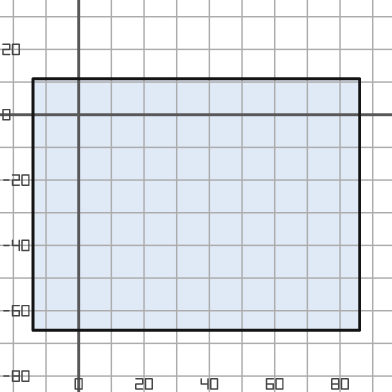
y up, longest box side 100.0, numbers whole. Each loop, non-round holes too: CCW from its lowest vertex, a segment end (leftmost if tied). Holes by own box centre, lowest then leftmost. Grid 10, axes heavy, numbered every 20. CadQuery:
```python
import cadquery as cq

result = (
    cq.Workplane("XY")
    .moveTo(-14.0, -66.0)
    .lineTo(86.0, -66.0)
    .lineTo(86.0, 11.0)
    .lineTo(-14.0, 11.0)
    .close()
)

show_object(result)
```